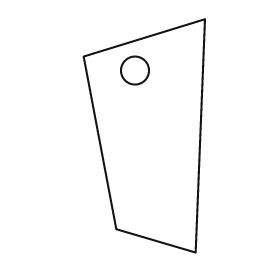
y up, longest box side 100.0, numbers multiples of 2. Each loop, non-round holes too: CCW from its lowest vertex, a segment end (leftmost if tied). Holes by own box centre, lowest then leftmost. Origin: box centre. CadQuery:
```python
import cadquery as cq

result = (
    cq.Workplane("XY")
    .moveTo(22.0, -50.0)
    .lineTo(26.0, 50.0)
    .lineTo(-26.0, 34.0)
    .lineTo(-12.0, -40.0)
    .close()
    .moveTo(-4.0, 28.0)
    .circle(6.0)
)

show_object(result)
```